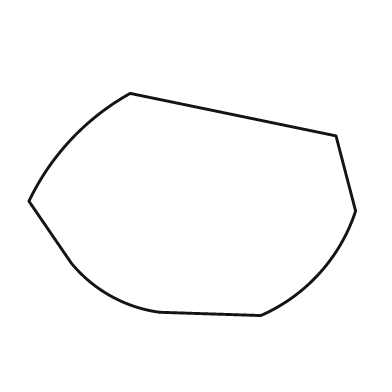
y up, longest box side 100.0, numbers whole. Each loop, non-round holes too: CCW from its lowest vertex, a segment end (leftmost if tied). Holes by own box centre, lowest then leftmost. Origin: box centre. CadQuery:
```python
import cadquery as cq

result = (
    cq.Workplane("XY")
    .moveTo(21.0, -34.0)
    .threePointArc((39.0, -21.0), (50.0, -2.0))
    .lineTo(44.0, 21.0)
    .lineTo(-19.0, 34.0)
    .threePointArc((-37.0, 20.0), (-50.0, 1.0))
    .lineTo(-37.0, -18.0)
    .threePointArc((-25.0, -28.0), (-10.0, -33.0))
    .close()
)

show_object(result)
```